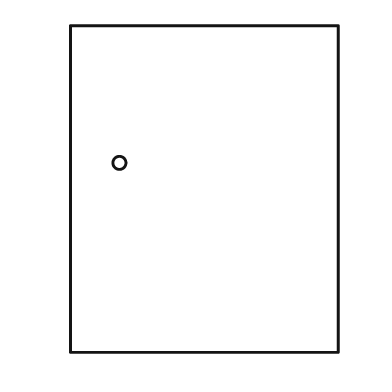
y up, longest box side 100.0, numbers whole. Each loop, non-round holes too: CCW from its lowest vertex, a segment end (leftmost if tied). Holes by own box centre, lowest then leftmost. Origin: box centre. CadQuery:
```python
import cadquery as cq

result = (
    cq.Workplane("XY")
    .moveTo(-41.0, -50.0)
    .lineTo(41.0, -50.0)
    .lineTo(41.0, 50.0)
    .lineTo(-41.0, 50.0)
    .close()
    .moveTo(-26.0, 8.0)
    .circle(2.0)
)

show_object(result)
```